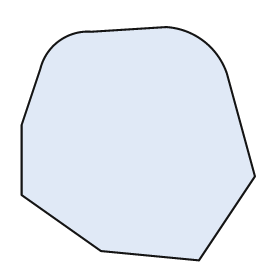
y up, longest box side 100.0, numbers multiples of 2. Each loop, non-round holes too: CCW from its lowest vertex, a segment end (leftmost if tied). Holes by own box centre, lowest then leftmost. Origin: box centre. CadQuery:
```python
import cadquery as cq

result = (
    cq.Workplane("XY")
    .moveTo(26.0, -50.0)
    .lineTo(50.0, -14.0)
    .lineTo(38.0, 30.0)
    .threePointArc((28.0, 44.0), (12.0, 50.0))
    .lineTo(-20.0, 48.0)
    .threePointArc((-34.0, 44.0), (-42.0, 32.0))
    .lineTo(-50.0, 8.0)
    .lineTo(-50.0, -22.0)
    .lineTo(-16.0, -46.0)
    .close()
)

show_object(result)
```